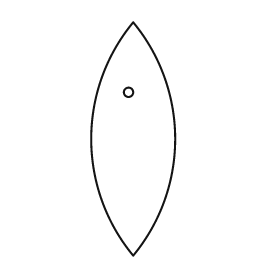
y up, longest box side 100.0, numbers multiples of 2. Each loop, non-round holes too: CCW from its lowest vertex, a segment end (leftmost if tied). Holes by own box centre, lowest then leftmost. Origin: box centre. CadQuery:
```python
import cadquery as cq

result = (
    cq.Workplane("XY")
    .moveTo(0.0, -50.0)
    .threePointArc((18.0, 0.0), (0.0, 50.0))
    .threePointArc((-18.0, 0.0), (0.0, -50.0))
    .close()
    .moveTo(-2.0, 20.0)
    .circle(2.0)
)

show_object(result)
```